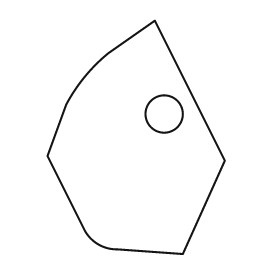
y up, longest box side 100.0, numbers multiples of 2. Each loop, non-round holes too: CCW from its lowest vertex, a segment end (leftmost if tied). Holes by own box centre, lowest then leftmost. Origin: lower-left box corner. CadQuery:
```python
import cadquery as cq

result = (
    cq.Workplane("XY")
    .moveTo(58.0, 0.0)
    .lineTo(76.0, 40.0)
    .lineTo(46.0, 100.0)
    .lineTo(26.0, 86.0)
    .threePointArc((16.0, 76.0), (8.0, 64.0))
    .lineTo(0.0, 42.0)
    .lineTo(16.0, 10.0)
    .threePointArc((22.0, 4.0), (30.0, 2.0))
    .close()
    .moveTo(50.0, 60.0)
    .circle(8.0)
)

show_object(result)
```